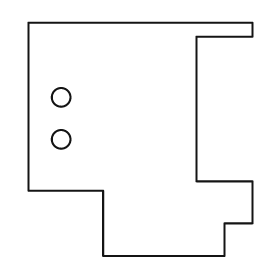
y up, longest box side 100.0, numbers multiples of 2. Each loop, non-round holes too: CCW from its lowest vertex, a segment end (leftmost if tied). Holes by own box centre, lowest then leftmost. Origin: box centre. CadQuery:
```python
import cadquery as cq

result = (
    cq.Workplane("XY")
    .moveTo(-16.0, -50.0)
    .lineTo(36.0, -50.0)
    .lineTo(36.0, -36.0)
    .lineTo(48.0, -36.0)
    .lineTo(48.0, -18.0)
    .lineTo(24.0, -18.0)
    .lineTo(24.0, 44.0)
    .lineTo(48.0, 44.0)
    .lineTo(48.0, 50.0)
    .lineTo(-48.0, 50.0)
    .lineTo(-48.0, -22.0)
    .lineTo(-16.0, -22.0)
    .close()
    .moveTo(-34.0, 0.0)
    .circle(4.0)
    .moveTo(-34.0, 18.0)
    .circle(4.0)
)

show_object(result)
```